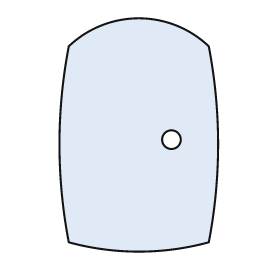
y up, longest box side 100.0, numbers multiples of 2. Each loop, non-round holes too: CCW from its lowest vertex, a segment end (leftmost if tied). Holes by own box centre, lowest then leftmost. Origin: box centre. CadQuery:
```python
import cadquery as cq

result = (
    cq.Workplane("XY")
    .moveTo(-30.0, -46.0)
    .threePointArc((0.0, -50.0), (30.0, -46.0))
    .threePointArc((34.0, -4.0), (30.0, 38.0))
    .threePointArc((0.0, 50.0), (-30.0, 38.0))
    .threePointArc((-34.0, -4.0), (-30.0, -46.0))
    .close()
    .moveTo(14.0, -2.0)
    .circle(4.0)
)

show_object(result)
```